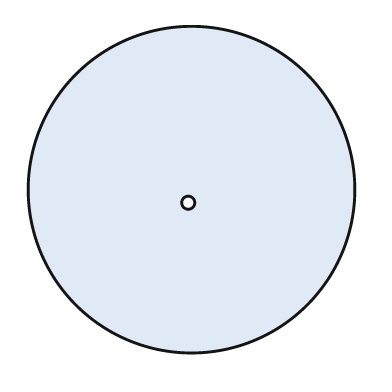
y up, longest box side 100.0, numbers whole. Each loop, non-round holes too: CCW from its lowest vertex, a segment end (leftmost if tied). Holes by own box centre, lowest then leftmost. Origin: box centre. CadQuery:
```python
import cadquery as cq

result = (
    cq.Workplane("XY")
    .moveTo(0.0, 0.0)
    .circle(50.0)
    .moveTo(-1.0, -4.0)
    .circle(2.0)
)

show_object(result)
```